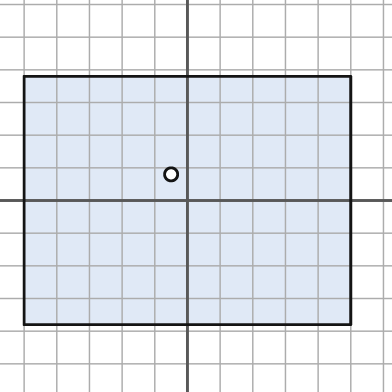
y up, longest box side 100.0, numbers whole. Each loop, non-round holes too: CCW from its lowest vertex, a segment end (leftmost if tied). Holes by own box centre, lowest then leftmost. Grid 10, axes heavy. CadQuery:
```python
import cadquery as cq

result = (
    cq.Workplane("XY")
    .moveTo(-50.0, -38.0)
    .lineTo(50.0, -38.0)
    .lineTo(50.0, 38.0)
    .lineTo(-50.0, 38.0)
    .close()
    .moveTo(-5.0, 8.0)
    .circle(2.0)
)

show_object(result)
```